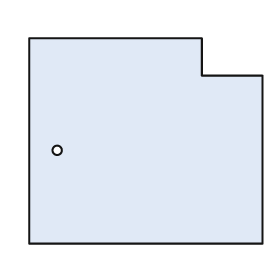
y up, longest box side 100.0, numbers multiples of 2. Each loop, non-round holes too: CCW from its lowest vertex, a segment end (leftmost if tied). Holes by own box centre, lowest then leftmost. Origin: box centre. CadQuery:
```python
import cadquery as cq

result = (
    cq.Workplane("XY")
    .moveTo(-50.0, -44.0)
    .lineTo(50.0, -44.0)
    .lineTo(50.0, 28.0)
    .lineTo(24.0, 28.0)
    .lineTo(24.0, 44.0)
    .lineTo(-50.0, 44.0)
    .close()
    .moveTo(-38.0, -4.0)
    .circle(2.0)
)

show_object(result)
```